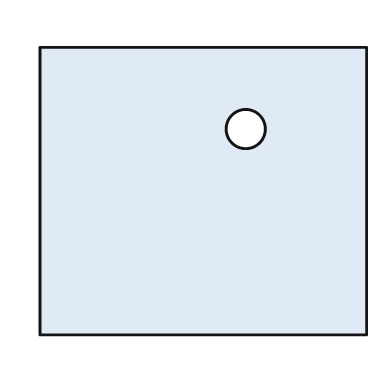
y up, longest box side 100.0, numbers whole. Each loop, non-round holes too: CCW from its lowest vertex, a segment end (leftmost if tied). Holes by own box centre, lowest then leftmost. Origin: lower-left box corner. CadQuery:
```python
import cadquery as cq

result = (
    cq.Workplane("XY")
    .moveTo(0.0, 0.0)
    .lineTo(100.0, 0.0)
    .lineTo(100.0, 88.0)
    .lineTo(0.0, 88.0)
    .close()
    .moveTo(63.0, 63.0)
    .circle(6.0)
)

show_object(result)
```